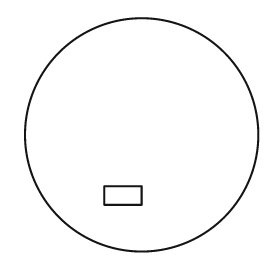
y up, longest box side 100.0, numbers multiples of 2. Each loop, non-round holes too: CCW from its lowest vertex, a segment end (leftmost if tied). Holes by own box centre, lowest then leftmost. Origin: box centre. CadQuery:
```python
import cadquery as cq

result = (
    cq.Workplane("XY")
    .moveTo(0.0, 0.0)
    .circle(50.0)
    .moveTo(-16.0, -30.0)
    .lineTo(0.0, -30.0)
    .lineTo(0.0, -22.0)
    .lineTo(-16.0, -22.0)
    .close()
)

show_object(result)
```